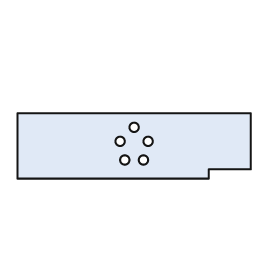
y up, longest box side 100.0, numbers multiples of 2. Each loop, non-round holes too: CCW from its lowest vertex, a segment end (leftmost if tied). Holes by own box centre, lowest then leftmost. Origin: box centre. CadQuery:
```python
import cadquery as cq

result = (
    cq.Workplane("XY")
    .moveTo(-50.0, -14.0)
    .lineTo(32.0, -14.0)
    .lineTo(32.0, -10.0)
    .lineTo(50.0, -10.0)
    .lineTo(50.0, 14.0)
    .lineTo(-50.0, 14.0)
    .close()
    .moveTo(-4.0, -6.0)
    .circle(2.0)
    .moveTo(4.0, -6.0)
    .circle(2.0)
    .moveTo(-6.0, 2.0)
    .circle(2.0)
    .moveTo(6.0, 2.0)
    .circle(2.0)
    .moveTo(0.0, 8.0)
    .circle(2.0)
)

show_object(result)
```